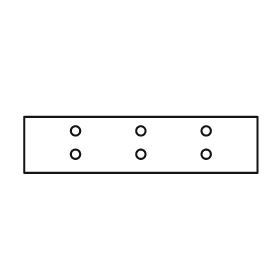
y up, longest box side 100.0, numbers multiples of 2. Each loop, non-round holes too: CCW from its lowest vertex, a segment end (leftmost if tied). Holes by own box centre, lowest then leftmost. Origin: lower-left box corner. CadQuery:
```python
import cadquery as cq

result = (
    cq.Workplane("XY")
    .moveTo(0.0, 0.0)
    .lineTo(100.0, 0.0)
    .lineTo(100.0, 24.0)
    .lineTo(0.0, 24.0)
    .close()
    .moveTo(22.0, 8.0)
    .circle(2.0)
    .moveTo(50.0, 8.0)
    .circle(2.0)
    .moveTo(78.0, 8.0)
    .circle(2.0)
    .moveTo(22.0, 18.0)
    .circle(2.0)
    .moveTo(50.0, 18.0)
    .circle(2.0)
    .moveTo(78.0, 18.0)
    .circle(2.0)
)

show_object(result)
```